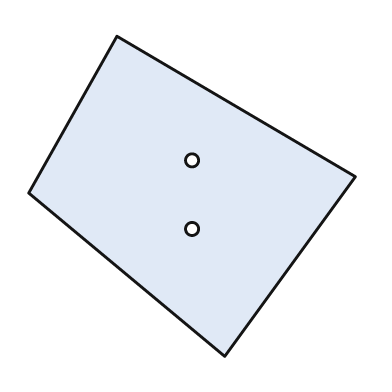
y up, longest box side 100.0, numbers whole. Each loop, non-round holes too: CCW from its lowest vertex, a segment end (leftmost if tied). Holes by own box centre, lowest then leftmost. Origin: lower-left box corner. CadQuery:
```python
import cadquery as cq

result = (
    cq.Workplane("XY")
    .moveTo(60.0, 0.0)
    .lineTo(100.0, 55.0)
    .lineTo(27.0, 98.0)
    .lineTo(0.0, 50.0)
    .close()
    .moveTo(50.0, 39.0)
    .circle(2.0)
    .moveTo(50.0, 60.0)
    .circle(2.0)
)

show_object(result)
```